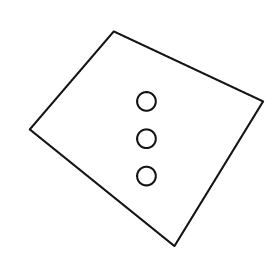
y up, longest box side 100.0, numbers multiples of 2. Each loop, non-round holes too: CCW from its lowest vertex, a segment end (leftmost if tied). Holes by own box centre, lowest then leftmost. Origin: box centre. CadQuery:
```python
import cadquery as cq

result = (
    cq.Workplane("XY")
    .moveTo(12.0, -46.0)
    .lineTo(50.0, 16.0)
    .lineTo(-14.0, 46.0)
    .lineTo(-50.0, 4.0)
    .close()
    .moveTo(0.0, -16.0)
    .circle(4.0)
    .moveTo(0.0, 0.0)
    .circle(4.0)
    .moveTo(0.0, 16.0)
    .circle(4.0)
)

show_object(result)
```